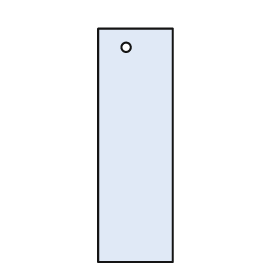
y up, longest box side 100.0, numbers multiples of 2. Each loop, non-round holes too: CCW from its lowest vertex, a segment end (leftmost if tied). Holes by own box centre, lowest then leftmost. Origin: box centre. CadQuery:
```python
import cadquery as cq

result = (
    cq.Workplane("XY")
    .moveTo(-16.0, -50.0)
    .lineTo(16.0, -50.0)
    .lineTo(16.0, 50.0)
    .lineTo(-16.0, 50.0)
    .close()
    .moveTo(-4.0, 42.0)
    .circle(2.0)
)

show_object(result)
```